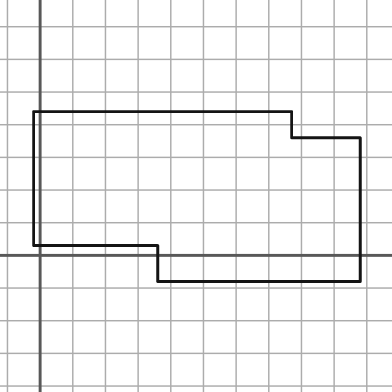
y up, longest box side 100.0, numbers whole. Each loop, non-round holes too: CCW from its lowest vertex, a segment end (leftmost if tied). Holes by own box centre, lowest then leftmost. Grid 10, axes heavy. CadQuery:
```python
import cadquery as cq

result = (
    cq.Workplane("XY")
    .moveTo(36.0, -8.0)
    .lineTo(98.0, -8.0)
    .lineTo(98.0, 36.0)
    .lineTo(77.0, 36.0)
    .lineTo(77.0, 44.0)
    .lineTo(-2.0, 44.0)
    .lineTo(-2.0, 3.0)
    .lineTo(36.0, 3.0)
    .close()
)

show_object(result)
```